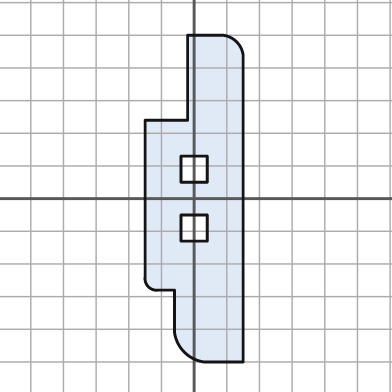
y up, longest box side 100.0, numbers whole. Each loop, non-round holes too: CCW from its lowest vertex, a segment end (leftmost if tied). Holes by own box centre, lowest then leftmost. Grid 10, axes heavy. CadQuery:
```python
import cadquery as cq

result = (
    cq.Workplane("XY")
    .moveTo(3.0, -50.0)
    .lineTo(15.0, -50.0)
    .lineTo(15.0, 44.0)
    .threePointArc((13.0, 48.0), (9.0, 50.0))
    .lineTo(-2.0, 50.0)
    .lineTo(-2.0, 24.0)
    .lineTo(-15.0, 24.0)
    .lineTo(-15.0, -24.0)
    .threePointArc((-14.0, -27.0), (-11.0, -28.0))
    .lineTo(-6.0, -28.0)
    .lineTo(-6.0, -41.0)
    .threePointArc((-3.0, -47.0), (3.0, -50.0))
    .close()
    .moveTo(-4.0, -13.0)
    .lineTo(4.0, -13.0)
    .lineTo(4.0, -5.0)
    .lineTo(-4.0, -5.0)
    .close()
    .moveTo(-4.0, 5.0)
    .lineTo(4.0, 5.0)
    .lineTo(4.0, 13.0)
    .lineTo(-4.0, 13.0)
    .close()
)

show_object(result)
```